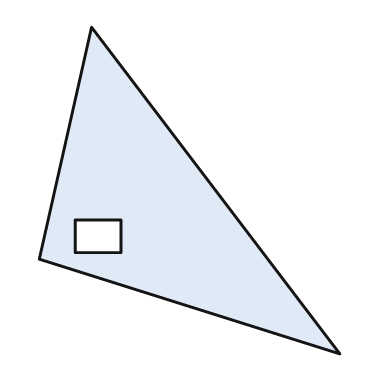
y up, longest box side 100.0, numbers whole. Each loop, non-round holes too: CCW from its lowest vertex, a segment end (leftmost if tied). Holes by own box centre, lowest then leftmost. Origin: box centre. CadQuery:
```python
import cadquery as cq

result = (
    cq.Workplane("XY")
    .moveTo(46.0, -50.0)
    .lineTo(-30.0, 50.0)
    .lineTo(-46.0, -21.0)
    .close()
    .moveTo(-35.0, -19.0)
    .lineTo(-21.0, -19.0)
    .lineTo(-21.0, -9.0)
    .lineTo(-35.0, -9.0)
    .close()
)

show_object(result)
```